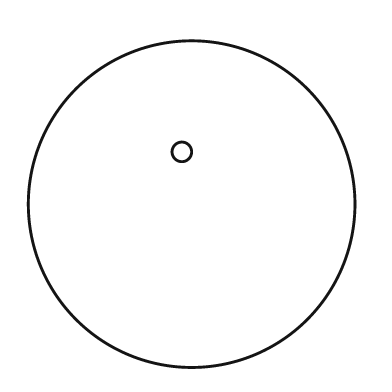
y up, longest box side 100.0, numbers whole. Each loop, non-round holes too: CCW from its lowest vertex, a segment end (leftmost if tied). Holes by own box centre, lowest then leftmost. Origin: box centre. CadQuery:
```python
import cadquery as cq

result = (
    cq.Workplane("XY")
    .moveTo(0.0, 0.0)
    .circle(50.0)
    .moveTo(-3.0, 16.0)
    .circle(3.0)
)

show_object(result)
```